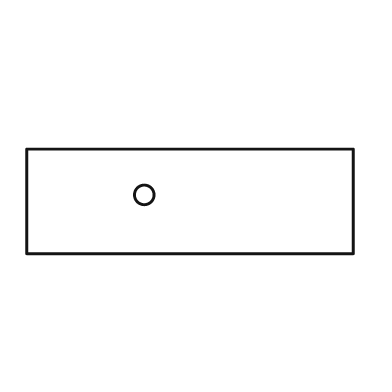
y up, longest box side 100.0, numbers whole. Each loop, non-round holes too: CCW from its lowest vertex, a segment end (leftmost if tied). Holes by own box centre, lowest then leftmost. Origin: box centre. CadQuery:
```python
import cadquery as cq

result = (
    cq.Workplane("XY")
    .moveTo(-50.0, -16.0)
    .lineTo(50.0, -16.0)
    .lineTo(50.0, 16.0)
    .lineTo(-50.0, 16.0)
    .close()
    .moveTo(-14.0, 2.0)
    .circle(3.0)
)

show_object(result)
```